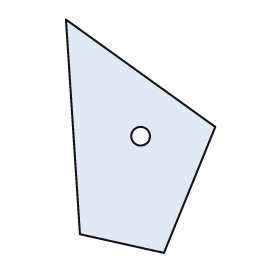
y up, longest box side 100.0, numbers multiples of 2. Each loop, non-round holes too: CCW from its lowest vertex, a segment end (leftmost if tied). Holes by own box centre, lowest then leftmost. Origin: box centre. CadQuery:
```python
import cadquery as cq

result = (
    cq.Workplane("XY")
    .moveTo(10.0, -50.0)
    .lineTo(32.0, 4.0)
    .lineTo(-32.0, 50.0)
    .lineTo(-26.0, -42.0)
    .close()
    .moveTo(0.0, 0.0)
    .circle(4.0)
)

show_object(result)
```